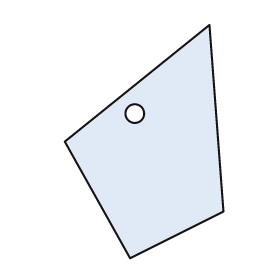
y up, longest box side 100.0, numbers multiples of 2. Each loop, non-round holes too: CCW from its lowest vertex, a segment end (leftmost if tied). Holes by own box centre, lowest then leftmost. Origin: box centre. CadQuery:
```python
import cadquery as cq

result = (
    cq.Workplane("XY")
    .moveTo(-6.0, -50.0)
    .lineTo(34.0, -30.0)
    .lineTo(28.0, 50.0)
    .lineTo(-34.0, 0.0)
    .close()
    .moveTo(-4.0, 12.0)
    .circle(4.0)
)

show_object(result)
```